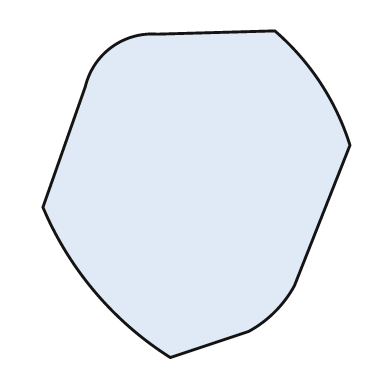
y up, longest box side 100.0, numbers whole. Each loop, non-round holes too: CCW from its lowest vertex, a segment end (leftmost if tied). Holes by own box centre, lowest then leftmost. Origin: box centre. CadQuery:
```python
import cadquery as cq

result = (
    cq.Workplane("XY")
    .moveTo(-8.0, -50.0)
    .lineTo(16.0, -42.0)
    .threePointArc((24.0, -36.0), (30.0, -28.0))
    .lineTo(47.0, 15.0)
    .threePointArc((38.0, 34.0), (24.0, 50.0))
    .lineTo(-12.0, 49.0)
    .threePointArc((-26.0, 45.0), (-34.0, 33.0))
    .lineTo(-47.0, -4.0)
    .threePointArc((-31.0, -30.0), (-8.0, -50.0))
    .close()
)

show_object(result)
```